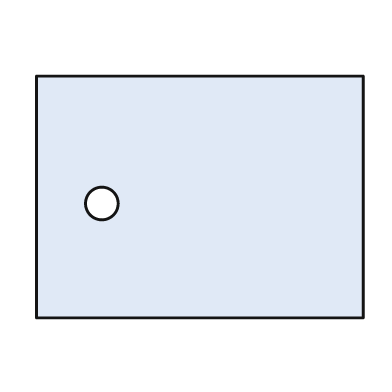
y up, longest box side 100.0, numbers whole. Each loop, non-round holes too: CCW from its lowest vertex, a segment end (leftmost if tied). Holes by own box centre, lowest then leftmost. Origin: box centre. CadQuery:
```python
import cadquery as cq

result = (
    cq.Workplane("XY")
    .moveTo(-50.0, -37.0)
    .lineTo(50.0, -37.0)
    .lineTo(50.0, 37.0)
    .lineTo(-50.0, 37.0)
    .close()
    .moveTo(-30.0, -2.0)
    .circle(5.0)
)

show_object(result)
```